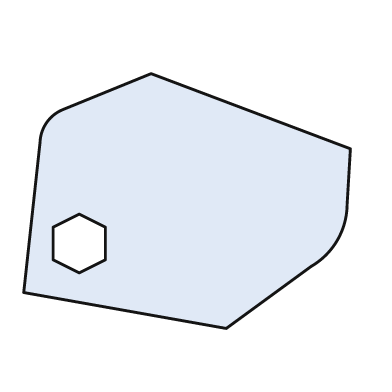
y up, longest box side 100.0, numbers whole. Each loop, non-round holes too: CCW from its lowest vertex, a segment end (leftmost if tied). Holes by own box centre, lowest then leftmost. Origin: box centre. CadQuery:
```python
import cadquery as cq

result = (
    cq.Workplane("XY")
    .moveTo(12.0, -39.0)
    .lineTo(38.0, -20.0)
    .threePointArc((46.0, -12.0), (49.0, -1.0))
    .lineTo(50.0, 16.0)
    .lineTo(-11.0, 39.0)
    .lineTo(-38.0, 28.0)
    .threePointArc((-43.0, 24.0), (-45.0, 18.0))
    .lineTo(-50.0, -28.0)
    .close()
    .moveTo(-33.0, -22.0)
    .lineTo(-25.0, -18.0)
    .lineTo(-25.0, -8.0)
    .lineTo(-33.0, -4.0)
    .lineTo(-41.0, -8.0)
    .lineTo(-41.0, -18.0)
    .close()
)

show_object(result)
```